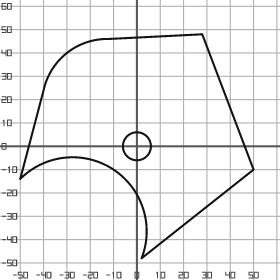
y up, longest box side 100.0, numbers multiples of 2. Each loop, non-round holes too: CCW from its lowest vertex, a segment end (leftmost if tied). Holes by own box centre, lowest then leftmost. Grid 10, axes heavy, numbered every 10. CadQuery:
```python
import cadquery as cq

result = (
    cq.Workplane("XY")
    .moveTo(2.0, -48.0)
    .lineTo(50.0, -10.0)
    .lineTo(28.0, 48.0)
    .lineTo(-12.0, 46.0)
    .threePointArc((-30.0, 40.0), (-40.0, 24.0))
    .lineTo(-50.0, -14.0)
    .threePointArc((-10.0, -10.0), (2.0, -48.0))
    .close()
    .moveTo(0.0, 0.0)
    .circle(6.0)
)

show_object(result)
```